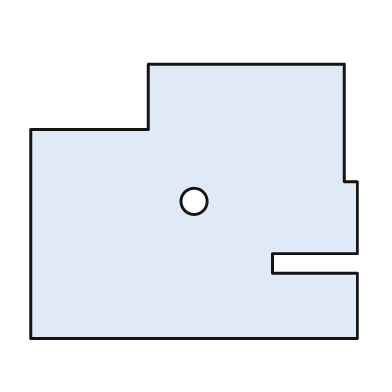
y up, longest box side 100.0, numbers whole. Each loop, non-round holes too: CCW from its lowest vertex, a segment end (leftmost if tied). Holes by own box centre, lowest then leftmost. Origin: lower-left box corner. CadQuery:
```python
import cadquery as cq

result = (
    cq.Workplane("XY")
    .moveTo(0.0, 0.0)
    .lineTo(100.0, 0.0)
    .lineTo(100.0, 20.0)
    .lineTo(74.0, 20.0)
    .lineTo(74.0, 26.0)
    .lineTo(100.0, 26.0)
    .lineTo(100.0, 48.0)
    .lineTo(96.0, 48.0)
    .lineTo(96.0, 84.0)
    .lineTo(36.0, 84.0)
    .lineTo(36.0, 64.0)
    .lineTo(0.0, 64.0)
    .close()
    .moveTo(50.0, 42.0)
    .circle(4.0)
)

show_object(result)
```